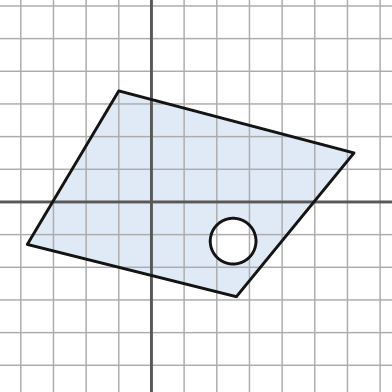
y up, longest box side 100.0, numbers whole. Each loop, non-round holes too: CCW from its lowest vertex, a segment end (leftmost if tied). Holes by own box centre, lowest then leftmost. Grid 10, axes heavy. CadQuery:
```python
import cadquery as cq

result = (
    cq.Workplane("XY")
    .moveTo(26.0, -29.0)
    .lineTo(62.0, 15.0)
    .lineTo(-10.0, 34.0)
    .lineTo(-38.0, -13.0)
    .close()
    .moveTo(25.0, -12.0)
    .circle(7.0)
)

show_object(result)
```